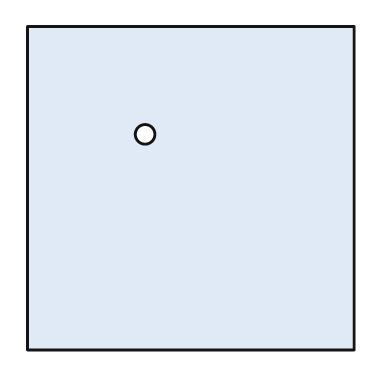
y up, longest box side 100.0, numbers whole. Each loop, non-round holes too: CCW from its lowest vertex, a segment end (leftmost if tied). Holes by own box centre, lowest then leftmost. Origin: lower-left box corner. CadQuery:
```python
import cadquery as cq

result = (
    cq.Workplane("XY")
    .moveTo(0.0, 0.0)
    .lineTo(100.0, 0.0)
    .lineTo(100.0, 99.0)
    .lineTo(0.0, 99.0)
    .close()
    .moveTo(36.0, 66.0)
    .circle(3.0)
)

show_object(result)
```